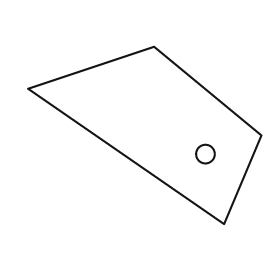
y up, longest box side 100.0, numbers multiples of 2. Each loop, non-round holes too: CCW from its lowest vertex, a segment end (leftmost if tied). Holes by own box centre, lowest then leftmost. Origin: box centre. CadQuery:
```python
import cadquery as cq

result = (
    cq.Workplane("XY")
    .moveTo(34.0, -38.0)
    .lineTo(50.0, 0.0)
    .lineTo(4.0, 38.0)
    .lineTo(-50.0, 20.0)
    .close()
    .moveTo(26.0, -8.0)
    .circle(4.0)
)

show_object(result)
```